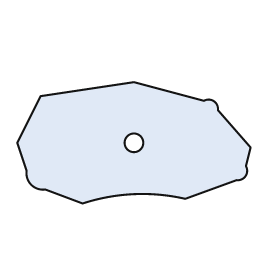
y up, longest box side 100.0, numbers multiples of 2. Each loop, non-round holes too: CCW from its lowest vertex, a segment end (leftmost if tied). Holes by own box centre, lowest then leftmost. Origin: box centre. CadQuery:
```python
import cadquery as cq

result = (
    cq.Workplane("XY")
    .moveTo(-22.0, -26.0)
    .threePointArc((0.0, -22.0), (22.0, -24.0))
    .lineTo(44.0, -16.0)
    .threePointArc((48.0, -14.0), (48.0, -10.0))
    .lineTo(50.0, -2.0)
    .lineTo(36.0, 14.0)
    .threePointArc((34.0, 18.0), (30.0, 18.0))
    .lineTo(0.0, 26.0)
    .lineTo(-40.0, 20.0)
    .lineTo(-50.0, 0.0)
    .lineTo(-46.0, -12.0)
    .threePointArc((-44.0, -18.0), (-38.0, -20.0))
    .close()
    .moveTo(0.0, 0.0)
    .circle(4.0)
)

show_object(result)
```